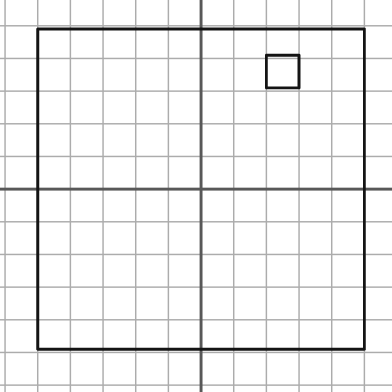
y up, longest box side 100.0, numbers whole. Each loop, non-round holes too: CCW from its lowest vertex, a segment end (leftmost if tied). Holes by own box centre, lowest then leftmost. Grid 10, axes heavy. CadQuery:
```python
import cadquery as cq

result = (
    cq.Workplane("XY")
    .moveTo(-50.0, -49.0)
    .lineTo(50.0, -49.0)
    .lineTo(50.0, 49.0)
    .lineTo(-50.0, 49.0)
    .close()
    .moveTo(20.0, 31.0)
    .lineTo(30.0, 31.0)
    .lineTo(30.0, 41.0)
    .lineTo(20.0, 41.0)
    .close()
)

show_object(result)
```